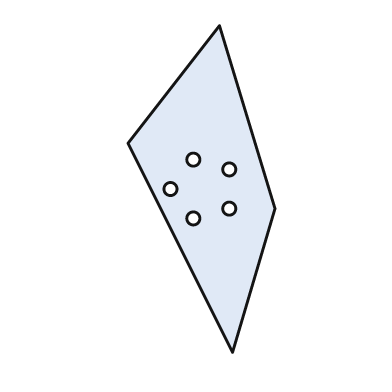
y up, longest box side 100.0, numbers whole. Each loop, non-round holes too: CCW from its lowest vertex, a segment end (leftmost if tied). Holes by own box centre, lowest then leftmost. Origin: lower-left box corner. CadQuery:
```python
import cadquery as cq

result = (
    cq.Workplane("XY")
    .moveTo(32.0, 0.0)
    .lineTo(45.0, 44.0)
    .lineTo(28.0, 100.0)
    .lineTo(0.0, 64.0)
    .close()
    .moveTo(20.0, 41.0)
    .circle(2.0)
    .moveTo(31.0, 44.0)
    .circle(2.0)
    .moveTo(13.0, 50.0)
    .circle(2.0)
    .moveTo(31.0, 56.0)
    .circle(2.0)
    .moveTo(20.0, 59.0)
    .circle(2.0)
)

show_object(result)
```